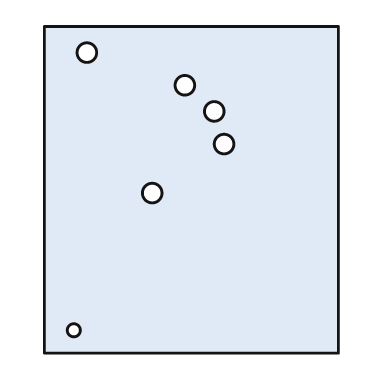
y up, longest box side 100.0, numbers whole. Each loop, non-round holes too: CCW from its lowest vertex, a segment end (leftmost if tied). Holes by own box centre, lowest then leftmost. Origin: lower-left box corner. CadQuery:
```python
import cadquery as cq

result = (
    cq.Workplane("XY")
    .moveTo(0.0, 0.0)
    .lineTo(90.0, 0.0)
    .lineTo(90.0, 100.0)
    .lineTo(0.0, 100.0)
    .close()
    .moveTo(9.0, 7.0)
    .circle(2.0)
    .moveTo(33.0, 49.0)
    .circle(3.0)
    .moveTo(55.0, 64.0)
    .circle(3.0)
    .moveTo(52.0, 74.0)
    .circle(3.0)
    .moveTo(43.0, 82.0)
    .circle(3.0)
    .moveTo(13.0, 92.0)
    .circle(3.0)
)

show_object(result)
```